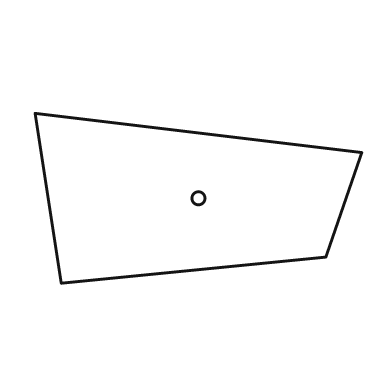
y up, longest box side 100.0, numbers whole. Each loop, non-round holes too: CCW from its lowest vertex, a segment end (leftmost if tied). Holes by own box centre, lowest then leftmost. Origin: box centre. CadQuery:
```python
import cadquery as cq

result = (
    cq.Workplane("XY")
    .moveTo(-42.0, -26.0)
    .lineTo(39.0, -18.0)
    .lineTo(50.0, 14.0)
    .lineTo(-50.0, 26.0)
    .close()
    .moveTo(0.0, 0.0)
    .circle(2.0)
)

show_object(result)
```